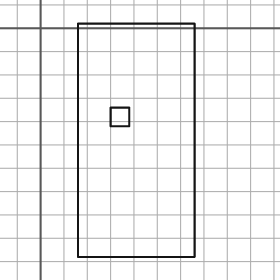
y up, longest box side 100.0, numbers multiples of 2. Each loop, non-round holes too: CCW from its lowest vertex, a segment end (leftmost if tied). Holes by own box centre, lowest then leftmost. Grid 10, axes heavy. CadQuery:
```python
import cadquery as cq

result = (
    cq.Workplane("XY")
    .moveTo(16.0, -98.0)
    .lineTo(66.0, -98.0)
    .lineTo(66.0, 2.0)
    .lineTo(16.0, 2.0)
    .close()
    .moveTo(30.0, -42.0)
    .lineTo(38.0, -42.0)
    .lineTo(38.0, -34.0)
    .lineTo(30.0, -34.0)
    .close()
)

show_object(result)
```